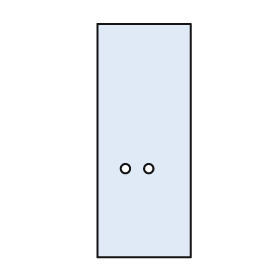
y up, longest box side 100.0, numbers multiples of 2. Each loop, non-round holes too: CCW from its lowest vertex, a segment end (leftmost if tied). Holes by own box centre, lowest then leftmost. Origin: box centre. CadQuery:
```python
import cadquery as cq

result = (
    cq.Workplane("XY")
    .moveTo(-20.0, -50.0)
    .lineTo(20.0, -50.0)
    .lineTo(20.0, 50.0)
    .lineTo(-20.0, 50.0)
    .close()
    .moveTo(-8.0, -12.0)
    .circle(2.0)
    .moveTo(2.0, -12.0)
    .circle(2.0)
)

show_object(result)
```